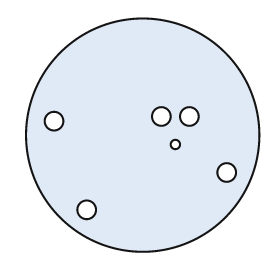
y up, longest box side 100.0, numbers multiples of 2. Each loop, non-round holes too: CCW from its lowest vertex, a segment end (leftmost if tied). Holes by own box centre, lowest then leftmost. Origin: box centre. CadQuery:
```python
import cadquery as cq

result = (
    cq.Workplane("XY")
    .moveTo(0.0, 0.0)
    .circle(50.0)
    .moveTo(-24.0, -32.0)
    .circle(4.0)
    .moveTo(36.0, -16.0)
    .circle(4.0)
    .moveTo(14.0, -4.0)
    .circle(2.0)
    .moveTo(-38.0, 6.0)
    .circle(4.0)
    .moveTo(8.0, 8.0)
    .circle(4.0)
    .moveTo(20.0, 8.0)
    .circle(4.0)
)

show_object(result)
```